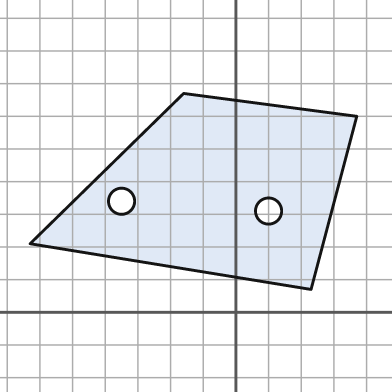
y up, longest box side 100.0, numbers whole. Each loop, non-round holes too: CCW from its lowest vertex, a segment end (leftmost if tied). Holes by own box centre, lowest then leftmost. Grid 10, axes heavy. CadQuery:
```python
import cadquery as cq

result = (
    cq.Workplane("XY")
    .moveTo(23.0, 7.0)
    .lineTo(37.0, 60.0)
    .lineTo(-16.0, 67.0)
    .lineTo(-63.0, 21.0)
    .close()
    .moveTo(10.0, 31.0)
    .circle(4.0)
    .moveTo(-35.0, 34.0)
    .circle(4.0)
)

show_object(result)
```